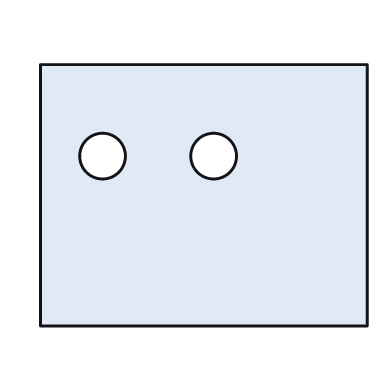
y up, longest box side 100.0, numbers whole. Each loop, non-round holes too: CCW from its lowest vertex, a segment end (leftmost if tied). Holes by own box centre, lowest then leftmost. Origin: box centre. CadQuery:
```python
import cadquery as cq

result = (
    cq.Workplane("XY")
    .moveTo(-50.0, -40.0)
    .lineTo(50.0, -40.0)
    .lineTo(50.0, 40.0)
    .lineTo(-50.0, 40.0)
    .close()
    .moveTo(-31.0, 12.0)
    .circle(7.0)
    .moveTo(3.0, 12.0)
    .circle(7.0)
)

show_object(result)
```